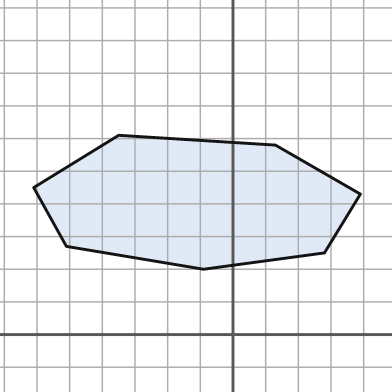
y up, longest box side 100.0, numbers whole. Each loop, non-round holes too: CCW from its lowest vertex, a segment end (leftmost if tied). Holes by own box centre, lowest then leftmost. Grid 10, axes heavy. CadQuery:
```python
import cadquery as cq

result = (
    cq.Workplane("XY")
    .moveTo(-9.0, 20.0)
    .lineTo(28.0, 25.0)
    .lineTo(39.0, 43.0)
    .lineTo(13.0, 58.0)
    .lineTo(-35.0, 61.0)
    .lineTo(-61.0, 45.0)
    .lineTo(-51.0, 27.0)
    .close()
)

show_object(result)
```